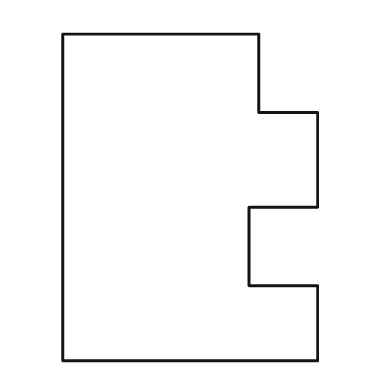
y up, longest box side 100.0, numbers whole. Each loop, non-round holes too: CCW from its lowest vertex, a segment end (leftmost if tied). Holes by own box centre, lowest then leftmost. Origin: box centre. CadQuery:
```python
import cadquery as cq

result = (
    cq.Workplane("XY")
    .moveTo(-39.0, -50.0)
    .lineTo(39.0, -50.0)
    .lineTo(39.0, -27.0)
    .lineTo(18.0, -27.0)
    .lineTo(18.0, -3.0)
    .lineTo(39.0, -3.0)
    .lineTo(39.0, 26.0)
    .lineTo(21.0, 26.0)
    .lineTo(21.0, 50.0)
    .lineTo(-39.0, 50.0)
    .close()
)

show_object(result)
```